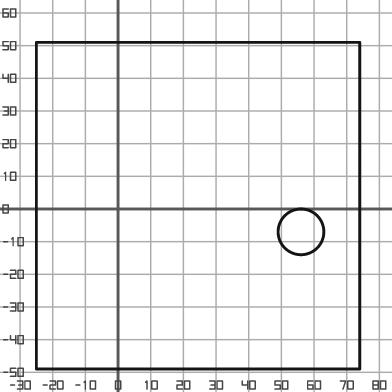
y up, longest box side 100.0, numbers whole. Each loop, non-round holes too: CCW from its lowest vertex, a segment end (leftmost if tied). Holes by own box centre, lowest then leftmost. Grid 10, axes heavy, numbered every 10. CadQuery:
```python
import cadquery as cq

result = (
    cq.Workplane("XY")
    .moveTo(-25.0, -49.0)
    .lineTo(74.0, -49.0)
    .lineTo(74.0, 51.0)
    .lineTo(-25.0, 51.0)
    .close()
    .moveTo(56.0, -7.0)
    .circle(7.0)
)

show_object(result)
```